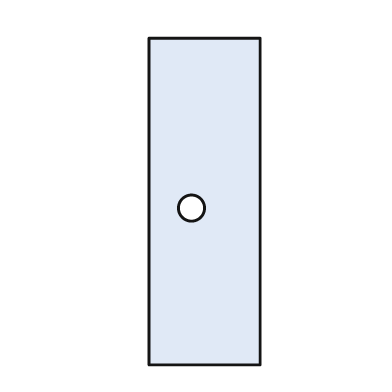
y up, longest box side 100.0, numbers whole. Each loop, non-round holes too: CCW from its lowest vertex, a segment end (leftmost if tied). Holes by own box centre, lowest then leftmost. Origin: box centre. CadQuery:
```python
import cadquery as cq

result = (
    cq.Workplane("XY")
    .moveTo(-17.0, -50.0)
    .lineTo(17.0, -50.0)
    .lineTo(17.0, 50.0)
    .lineTo(-17.0, 50.0)
    .close()
    .moveTo(-4.0, -2.0)
    .circle(4.0)
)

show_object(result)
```